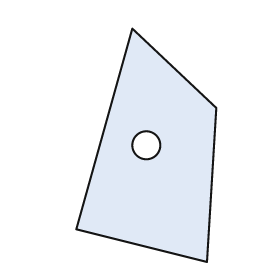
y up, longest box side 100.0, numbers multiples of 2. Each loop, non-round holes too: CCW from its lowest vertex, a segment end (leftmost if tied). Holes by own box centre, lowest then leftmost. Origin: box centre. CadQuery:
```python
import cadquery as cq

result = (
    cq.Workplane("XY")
    .moveTo(26.0, -50.0)
    .lineTo(30.0, 16.0)
    .lineTo(-6.0, 50.0)
    .lineTo(-30.0, -36.0)
    .close()
    .moveTo(0.0, 0.0)
    .circle(6.0)
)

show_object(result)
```